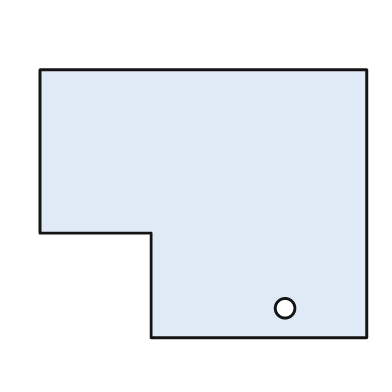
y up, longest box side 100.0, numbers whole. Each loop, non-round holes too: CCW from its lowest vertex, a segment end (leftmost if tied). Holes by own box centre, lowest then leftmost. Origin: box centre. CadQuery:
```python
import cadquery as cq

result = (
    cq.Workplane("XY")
    .moveTo(-16.0, -41.0)
    .lineTo(50.0, -41.0)
    .lineTo(50.0, 41.0)
    .lineTo(-50.0, 41.0)
    .lineTo(-50.0, -9.0)
    .lineTo(-16.0, -9.0)
    .close()
    .moveTo(25.0, -32.0)
    .circle(3.0)
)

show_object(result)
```